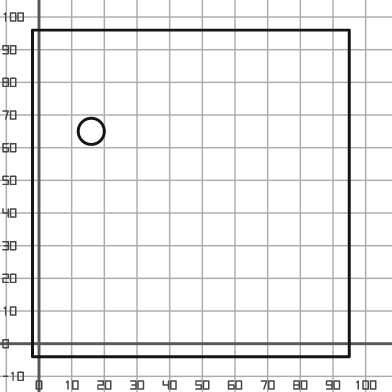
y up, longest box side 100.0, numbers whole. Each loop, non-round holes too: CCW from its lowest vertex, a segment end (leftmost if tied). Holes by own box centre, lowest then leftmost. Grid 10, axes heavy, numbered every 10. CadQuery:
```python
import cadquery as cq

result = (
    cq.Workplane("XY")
    .moveTo(-2.0, -4.0)
    .lineTo(95.0, -4.0)
    .lineTo(95.0, 96.0)
    .lineTo(-2.0, 96.0)
    .close()
    .moveTo(16.0, 65.0)
    .circle(4.0)
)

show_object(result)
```